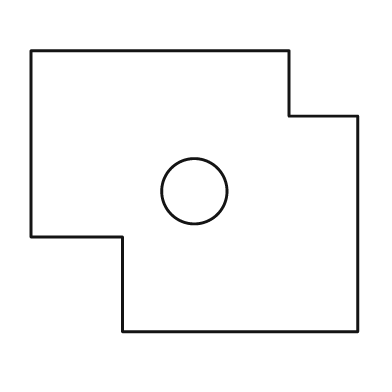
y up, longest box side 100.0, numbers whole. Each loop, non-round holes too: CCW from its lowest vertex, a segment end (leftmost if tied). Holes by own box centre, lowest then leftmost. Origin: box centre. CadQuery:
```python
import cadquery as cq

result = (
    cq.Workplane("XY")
    .moveTo(-22.0, -43.0)
    .lineTo(50.0, -43.0)
    .lineTo(50.0, 23.0)
    .lineTo(29.0, 23.0)
    .lineTo(29.0, 43.0)
    .lineTo(-50.0, 43.0)
    .lineTo(-50.0, -14.0)
    .lineTo(-22.0, -14.0)
    .close()
    .moveTo(0.0, 0.0)
    .circle(10.0)
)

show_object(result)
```